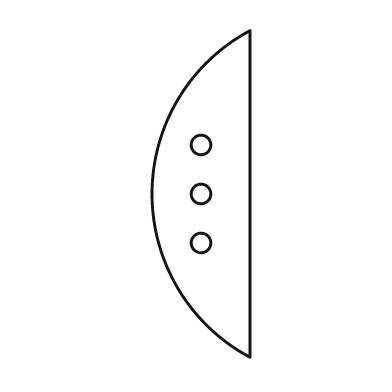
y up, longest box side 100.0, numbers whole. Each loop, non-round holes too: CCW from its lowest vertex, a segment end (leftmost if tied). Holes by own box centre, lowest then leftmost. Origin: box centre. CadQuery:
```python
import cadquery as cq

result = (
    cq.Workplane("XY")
    .moveTo(15.0, -50.0)
    .lineTo(15.0, 50.0)
    .threePointArc((-15.0, 0.0), (15.0, -50.0))
    .close()
    .moveTo(0.0, -15.0)
    .circle(3.0)
    .moveTo(0.0, 0.0)
    .circle(3.0)
    .moveTo(0.0, 15.0)
    .circle(3.0)
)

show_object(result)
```